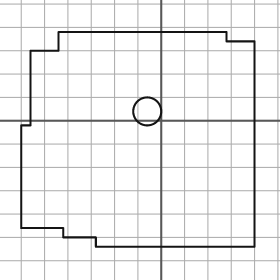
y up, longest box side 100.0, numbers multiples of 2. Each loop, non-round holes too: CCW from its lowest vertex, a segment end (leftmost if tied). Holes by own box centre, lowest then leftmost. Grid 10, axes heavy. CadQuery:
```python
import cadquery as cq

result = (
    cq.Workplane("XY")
    .moveTo(-28.0, -54.0)
    .lineTo(40.0, -54.0)
    .lineTo(40.0, 34.0)
    .lineTo(28.0, 34.0)
    .lineTo(28.0, 38.0)
    .lineTo(-44.0, 38.0)
    .lineTo(-44.0, 30.0)
    .lineTo(-56.0, 30.0)
    .lineTo(-56.0, -2.0)
    .lineTo(-60.0, -2.0)
    .lineTo(-60.0, -46.0)
    .lineTo(-42.0, -46.0)
    .lineTo(-42.0, -50.0)
    .lineTo(-28.0, -50.0)
    .close()
    .moveTo(-6.0, 4.0)
    .circle(6.0)
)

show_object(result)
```